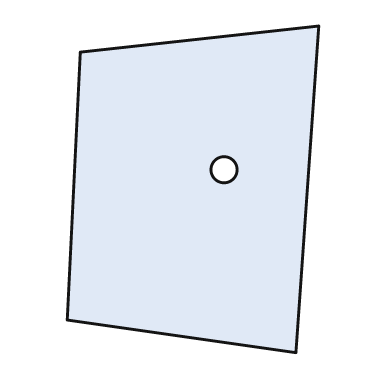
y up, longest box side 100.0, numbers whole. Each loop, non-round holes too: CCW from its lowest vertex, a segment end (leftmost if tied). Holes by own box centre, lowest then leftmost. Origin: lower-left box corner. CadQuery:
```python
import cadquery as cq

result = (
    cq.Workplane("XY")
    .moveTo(70.0, 0.0)
    .lineTo(77.0, 100.0)
    .lineTo(4.0, 92.0)
    .lineTo(0.0, 10.0)
    .close()
    .moveTo(48.0, 56.0)
    .circle(4.0)
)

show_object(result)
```